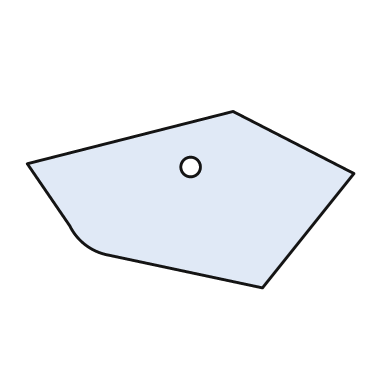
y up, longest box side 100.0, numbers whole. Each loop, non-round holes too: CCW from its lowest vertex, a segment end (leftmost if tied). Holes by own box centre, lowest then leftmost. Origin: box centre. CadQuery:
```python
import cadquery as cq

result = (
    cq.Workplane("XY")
    .moveTo(22.0, -27.0)
    .lineTo(50.0, 8.0)
    .lineTo(13.0, 27.0)
    .lineTo(-50.0, 11.0)
    .lineTo(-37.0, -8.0)
    .threePointArc((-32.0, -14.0), (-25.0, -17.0))
    .close()
    .moveTo(0.0, 10.0)
    .circle(3.0)
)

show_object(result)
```